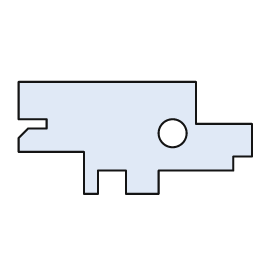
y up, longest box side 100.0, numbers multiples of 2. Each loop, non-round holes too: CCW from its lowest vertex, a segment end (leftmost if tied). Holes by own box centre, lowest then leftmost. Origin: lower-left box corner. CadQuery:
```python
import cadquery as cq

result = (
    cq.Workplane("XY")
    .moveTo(28.0, 0.0)
    .lineTo(34.0, 0.0)
    .lineTo(34.0, 10.0)
    .lineTo(46.0, 10.0)
    .lineTo(46.0, 0.0)
    .lineTo(60.0, 0.0)
    .lineTo(60.0, 10.0)
    .lineTo(92.0, 10.0)
    .lineTo(92.0, 16.0)
    .lineTo(100.0, 16.0)
    .lineTo(100.0, 30.0)
    .lineTo(76.0, 30.0)
    .lineTo(76.0, 48.0)
    .lineTo(0.0, 48.0)
    .lineTo(0.0, 32.0)
    .lineTo(12.0, 32.0)
    .lineTo(12.0, 28.0)
    .lineTo(4.0, 28.0)
    .lineTo(0.0, 24.0)
    .lineTo(0.0, 18.0)
    .lineTo(28.0, 18.0)
    .close()
    .moveTo(66.0, 26.0)
    .circle(6.0)
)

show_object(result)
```